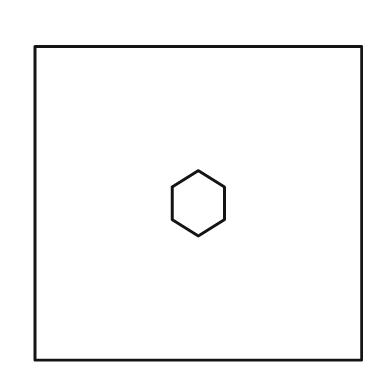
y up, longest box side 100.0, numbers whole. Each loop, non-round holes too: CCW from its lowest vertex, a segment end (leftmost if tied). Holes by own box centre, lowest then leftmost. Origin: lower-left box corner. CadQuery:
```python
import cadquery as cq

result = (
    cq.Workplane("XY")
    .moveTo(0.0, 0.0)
    .lineTo(100.0, 0.0)
    .lineTo(100.0, 96.0)
    .lineTo(0.0, 96.0)
    .close()
    .moveTo(50.0, 38.0)
    .lineTo(58.0, 43.0)
    .lineTo(58.0, 53.0)
    .lineTo(50.0, 58.0)
    .lineTo(42.0, 53.0)
    .lineTo(42.0, 43.0)
    .close()
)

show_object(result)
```